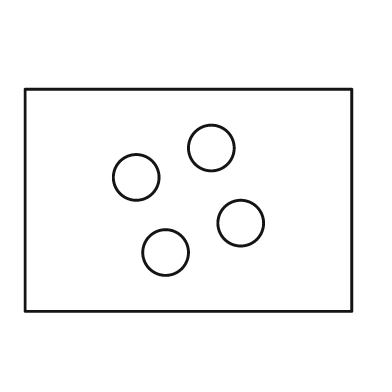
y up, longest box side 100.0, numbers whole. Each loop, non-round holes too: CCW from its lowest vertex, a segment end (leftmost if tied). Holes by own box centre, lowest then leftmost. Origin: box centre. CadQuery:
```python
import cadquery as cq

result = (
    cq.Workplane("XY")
    .moveTo(-50.0, -34.0)
    .lineTo(50.0, -34.0)
    .lineTo(50.0, 34.0)
    .lineTo(-50.0, 34.0)
    .close()
    .moveTo(-7.0, -16.0)
    .circle(7.0)
    .moveTo(16.0, -7.0)
    .circle(7.0)
    .moveTo(-16.0, 7.0)
    .circle(7.0)
    .moveTo(7.0, 16.0)
    .circle(7.0)
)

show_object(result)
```